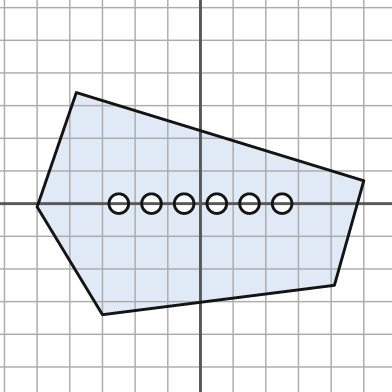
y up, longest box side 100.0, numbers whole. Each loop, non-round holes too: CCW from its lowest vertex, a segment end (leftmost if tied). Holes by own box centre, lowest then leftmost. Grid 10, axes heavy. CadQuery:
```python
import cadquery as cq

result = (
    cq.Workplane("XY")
    .moveTo(-30.0, -34.0)
    .lineTo(41.0, -25.0)
    .lineTo(50.0, 7.0)
    .lineTo(-38.0, 34.0)
    .lineTo(-50.0, -1.0)
    .close()
    .moveTo(-25.0, 0.0)
    .circle(3.0)
    .moveTo(-15.0, 0.0)
    .circle(3.0)
    .moveTo(-5.0, 0.0)
    .circle(3.0)
    .moveTo(5.0, 0.0)
    .circle(3.0)
    .moveTo(15.0, 0.0)
    .circle(3.0)
    .moveTo(25.0, 0.0)
    .circle(3.0)
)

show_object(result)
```